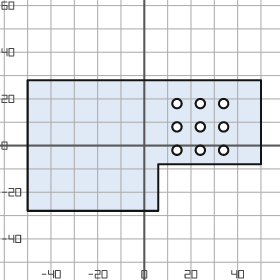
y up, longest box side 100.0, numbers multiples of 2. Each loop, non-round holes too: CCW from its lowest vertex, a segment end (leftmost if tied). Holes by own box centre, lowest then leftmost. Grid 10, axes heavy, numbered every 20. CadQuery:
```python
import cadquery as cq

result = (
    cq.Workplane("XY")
    .moveTo(-50.0, -28.0)
    .lineTo(6.0, -28.0)
    .lineTo(6.0, -8.0)
    .lineTo(50.0, -8.0)
    .lineTo(50.0, 28.0)
    .lineTo(-50.0, 28.0)
    .close()
    .moveTo(14.0, -2.0)
    .circle(2.0)
    .moveTo(24.0, -2.0)
    .circle(2.0)
    .moveTo(34.0, -2.0)
    .circle(2.0)
    .moveTo(14.0, 8.0)
    .circle(2.0)
    .moveTo(24.0, 8.0)
    .circle(2.0)
    .moveTo(34.0, 8.0)
    .circle(2.0)
    .moveTo(14.0, 18.0)
    .circle(2.0)
    .moveTo(24.0, 18.0)
    .circle(2.0)
    .moveTo(34.0, 18.0)
    .circle(2.0)
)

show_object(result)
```